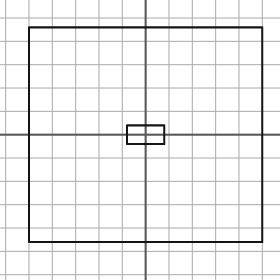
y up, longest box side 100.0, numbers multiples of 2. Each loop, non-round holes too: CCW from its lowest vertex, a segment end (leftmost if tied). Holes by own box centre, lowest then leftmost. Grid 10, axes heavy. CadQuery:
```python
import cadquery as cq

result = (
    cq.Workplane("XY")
    .moveTo(-50.0, -46.0)
    .lineTo(50.0, -46.0)
    .lineTo(50.0, 46.0)
    .lineTo(-50.0, 46.0)
    .close()
    .moveTo(-8.0, -4.0)
    .lineTo(8.0, -4.0)
    .lineTo(8.0, 4.0)
    .lineTo(-8.0, 4.0)
    .close()
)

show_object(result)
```